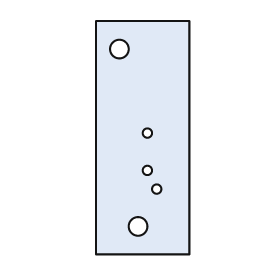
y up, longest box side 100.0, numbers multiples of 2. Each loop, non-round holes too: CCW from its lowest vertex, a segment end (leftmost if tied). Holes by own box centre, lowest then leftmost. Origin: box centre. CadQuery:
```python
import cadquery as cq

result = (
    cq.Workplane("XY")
    .moveTo(-20.0, -50.0)
    .lineTo(20.0, -50.0)
    .lineTo(20.0, 50.0)
    .lineTo(-20.0, 50.0)
    .close()
    .moveTo(-2.0, -38.0)
    .circle(4.0)
    .moveTo(6.0, -22.0)
    .circle(2.0)
    .moveTo(2.0, -14.0)
    .circle(2.0)
    .moveTo(2.0, 2.0)
    .circle(2.0)
    .moveTo(-10.0, 38.0)
    .circle(4.0)
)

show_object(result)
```